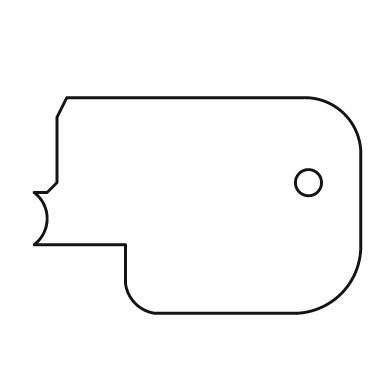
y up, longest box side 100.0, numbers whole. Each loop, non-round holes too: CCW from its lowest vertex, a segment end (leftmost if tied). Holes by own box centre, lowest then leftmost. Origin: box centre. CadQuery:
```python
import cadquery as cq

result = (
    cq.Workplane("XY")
    .moveTo(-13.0, -33.0)
    .lineTo(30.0, -33.0)
    .threePointArc((44.0, -27.0), (50.0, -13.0))
    .lineTo(50.0, 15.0)
    .threePointArc((45.0, 28.0), (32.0, 33.0))
    .lineTo(-40.0, 33.0)
    .lineTo(-43.0, 27.0)
    .lineTo(-43.0, 7.0)
    .lineTo(-46.0, 4.0)
    .lineTo(-50.0, 4.0)
    .threePointArc((-46.0, -4.0), (-50.0, -12.0))
    .lineTo(-22.0, -12.0)
    .lineTo(-22.0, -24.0)
    .threePointArc((-19.0, -30.0), (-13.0, -33.0))
    .close()
    .moveTo(34.0, 7.0)
    .circle(4.0)
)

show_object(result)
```